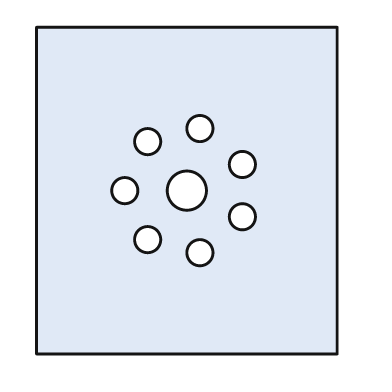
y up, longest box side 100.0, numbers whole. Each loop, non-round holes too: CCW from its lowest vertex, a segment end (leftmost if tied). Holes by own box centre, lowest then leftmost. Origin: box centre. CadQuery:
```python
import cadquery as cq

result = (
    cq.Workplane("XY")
    .moveTo(-46.0, -50.0)
    .lineTo(46.0, -50.0)
    .lineTo(46.0, 50.0)
    .lineTo(-46.0, 50.0)
    .close()
    .moveTo(4.0, -19.0)
    .circle(4.0)
    .moveTo(-12.0, -15.0)
    .circle(4.0)
    .moveTo(17.0, -8.0)
    .circle(4.0)
    .moveTo(-19.0, 0.0)
    .circle(4.0)
    .moveTo(0.0, 0.0)
    .circle(6.0)
    .moveTo(17.0, 8.0)
    .circle(4.0)
    .moveTo(-12.0, 15.0)
    .circle(4.0)
    .moveTo(4.0, 19.0)
    .circle(4.0)
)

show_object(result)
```